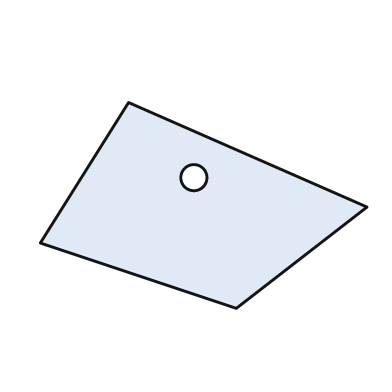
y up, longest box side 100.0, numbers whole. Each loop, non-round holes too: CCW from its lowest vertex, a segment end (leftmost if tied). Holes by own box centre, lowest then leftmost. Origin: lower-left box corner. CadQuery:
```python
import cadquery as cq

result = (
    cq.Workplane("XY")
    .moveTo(60.0, 0.0)
    .lineTo(100.0, 31.0)
    .lineTo(27.0, 63.0)
    .lineTo(0.0, 20.0)
    .close()
    .moveTo(47.0, 40.0)
    .circle(4.0)
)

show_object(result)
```